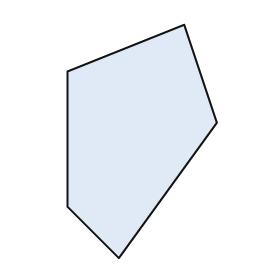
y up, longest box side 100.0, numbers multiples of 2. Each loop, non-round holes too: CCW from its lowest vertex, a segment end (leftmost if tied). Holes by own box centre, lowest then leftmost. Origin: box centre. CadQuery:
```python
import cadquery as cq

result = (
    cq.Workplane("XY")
    .moveTo(-10.0, -50.0)
    .lineTo(32.0, 8.0)
    .lineTo(18.0, 50.0)
    .lineTo(-32.0, 30.0)
    .lineTo(-32.0, -28.0)
    .close()
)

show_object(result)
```